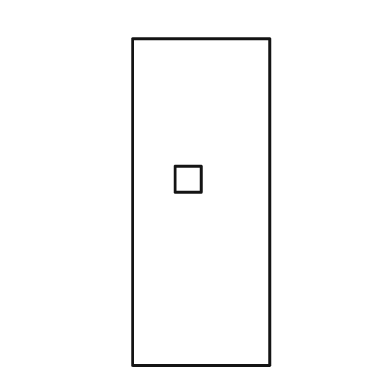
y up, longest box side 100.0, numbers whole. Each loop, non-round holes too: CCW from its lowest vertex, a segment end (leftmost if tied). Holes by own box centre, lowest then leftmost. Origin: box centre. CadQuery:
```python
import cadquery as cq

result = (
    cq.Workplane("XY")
    .moveTo(-21.0, -50.0)
    .lineTo(21.0, -50.0)
    .lineTo(21.0, 50.0)
    .lineTo(-21.0, 50.0)
    .close()
    .moveTo(-8.0, 3.0)
    .lineTo(0.0, 3.0)
    .lineTo(0.0, 11.0)
    .lineTo(-8.0, 11.0)
    .close()
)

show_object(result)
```